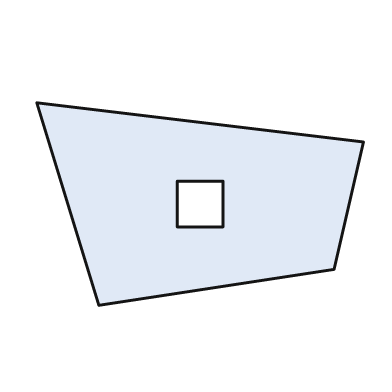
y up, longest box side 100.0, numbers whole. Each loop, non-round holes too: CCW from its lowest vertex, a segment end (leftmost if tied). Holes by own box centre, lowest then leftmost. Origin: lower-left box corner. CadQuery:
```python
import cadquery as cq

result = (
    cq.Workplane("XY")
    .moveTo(19.0, 0.0)
    .lineTo(91.0, 11.0)
    .lineTo(100.0, 50.0)
    .lineTo(0.0, 62.0)
    .close()
    .moveTo(43.0, 24.0)
    .lineTo(57.0, 24.0)
    .lineTo(57.0, 38.0)
    .lineTo(43.0, 38.0)
    .close()
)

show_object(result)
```